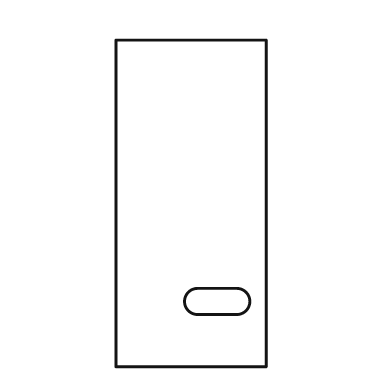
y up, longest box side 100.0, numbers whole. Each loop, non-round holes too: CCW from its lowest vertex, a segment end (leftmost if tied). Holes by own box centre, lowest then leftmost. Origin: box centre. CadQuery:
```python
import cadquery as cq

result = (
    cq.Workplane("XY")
    .moveTo(-23.0, -50.0)
    .lineTo(23.0, -50.0)
    .lineTo(23.0, 50.0)
    .lineTo(-23.0, 50.0)
    .close()
    .moveTo(2.0, -34.0)
    .lineTo(14.0, -34.0)
    .threePointArc((18.0, -30.0), (14.0, -26.0))
    .lineTo(2.0, -26.0)
    .threePointArc((-2.0, -30.0), (2.0, -34.0))
    .close()
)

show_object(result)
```